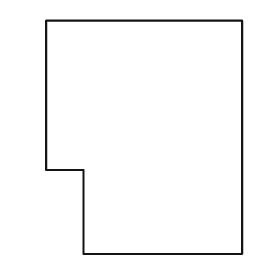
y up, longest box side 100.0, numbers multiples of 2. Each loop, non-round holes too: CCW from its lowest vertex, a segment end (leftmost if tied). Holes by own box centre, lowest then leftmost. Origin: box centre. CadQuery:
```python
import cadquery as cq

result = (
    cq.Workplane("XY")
    .moveTo(-26.0, -50.0)
    .lineTo(42.0, -50.0)
    .lineTo(42.0, 50.0)
    .lineTo(-42.0, 50.0)
    .lineTo(-42.0, -14.0)
    .lineTo(-26.0, -14.0)
    .close()
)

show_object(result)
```